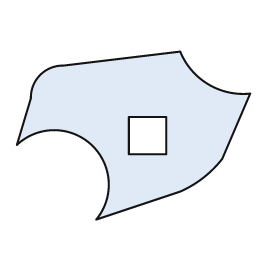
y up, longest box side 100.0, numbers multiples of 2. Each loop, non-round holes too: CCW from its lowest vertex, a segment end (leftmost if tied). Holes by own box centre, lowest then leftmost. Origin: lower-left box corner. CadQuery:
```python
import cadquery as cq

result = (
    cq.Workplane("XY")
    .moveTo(34.0, 0.0)
    .lineTo(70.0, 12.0)
    .threePointArc((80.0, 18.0), (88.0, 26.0))
    .lineTo(100.0, 54.0)
    .threePointArc((82.0, 58.0), (70.0, 72.0))
    .lineTo(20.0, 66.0)
    .threePointArc((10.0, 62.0), (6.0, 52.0))
    .lineTo(0.0, 32.0)
    .threePointArc((32.0, 32.0), (34.0, 0.0))
    .close()
    .moveTo(48.0, 28.0)
    .lineTo(64.0, 28.0)
    .lineTo(64.0, 44.0)
    .lineTo(48.0, 44.0)
    .close()
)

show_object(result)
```